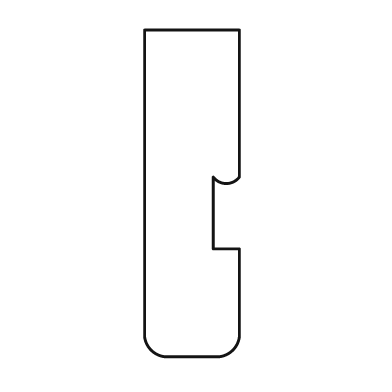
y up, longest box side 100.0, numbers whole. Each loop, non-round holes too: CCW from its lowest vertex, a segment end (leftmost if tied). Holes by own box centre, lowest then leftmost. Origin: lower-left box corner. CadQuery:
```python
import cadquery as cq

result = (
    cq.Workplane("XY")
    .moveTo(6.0, 0.0)
    .lineTo(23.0, 0.0)
    .threePointArc((27.0, 2.0), (29.0, 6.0))
    .lineTo(29.0, 33.0)
    .lineTo(21.0, 33.0)
    .lineTo(21.0, 55.0)
    .threePointArc((25.0, 53.0), (29.0, 55.0))
    .lineTo(29.0, 100.0)
    .lineTo(0.0, 100.0)
    .lineTo(0.0, 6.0)
    .threePointArc((2.0, 2.0), (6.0, 0.0))
    .close()
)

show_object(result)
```